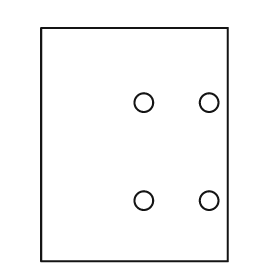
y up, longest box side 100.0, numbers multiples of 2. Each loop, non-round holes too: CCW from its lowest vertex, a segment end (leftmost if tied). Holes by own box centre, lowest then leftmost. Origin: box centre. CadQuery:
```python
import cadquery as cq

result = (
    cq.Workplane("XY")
    .moveTo(-40.0, -50.0)
    .lineTo(40.0, -50.0)
    .lineTo(40.0, 50.0)
    .lineTo(-40.0, 50.0)
    .close()
    .moveTo(4.0, -24.0)
    .circle(4.0)
    .moveTo(32.0, -24.0)
    .circle(4.0)
    .moveTo(4.0, 18.0)
    .circle(4.0)
    .moveTo(32.0, 18.0)
    .circle(4.0)
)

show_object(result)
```